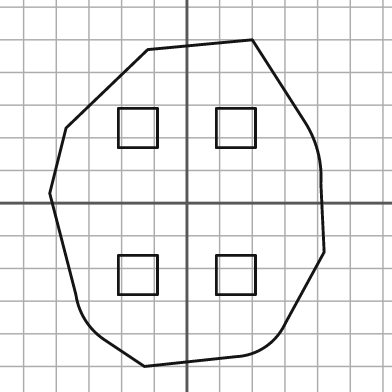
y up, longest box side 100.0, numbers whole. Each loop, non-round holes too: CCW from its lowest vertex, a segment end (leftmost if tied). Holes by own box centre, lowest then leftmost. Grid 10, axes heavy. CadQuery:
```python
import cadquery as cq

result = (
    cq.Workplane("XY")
    .moveTo(-13.0, -50.0)
    .lineTo(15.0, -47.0)
    .threePointArc((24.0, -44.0), (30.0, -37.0))
    .lineTo(42.0, -15.0)
    .lineTo(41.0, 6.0)
    .threePointArc((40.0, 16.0), (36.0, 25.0))
    .lineTo(20.0, 50.0)
    .lineTo(-12.0, 47.0)
    .lineTo(-37.0, 23.0)
    .lineTo(-42.0, 3.0)
    .lineTo(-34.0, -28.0)
    .threePointArc((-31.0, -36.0), (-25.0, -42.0))
    .close()
    .moveTo(-21.0, -28.0)
    .lineTo(-9.0, -28.0)
    .lineTo(-9.0, -16.0)
    .lineTo(-21.0, -16.0)
    .close()
    .moveTo(9.0, -28.0)
    .lineTo(21.0, -28.0)
    .lineTo(21.0, -16.0)
    .lineTo(9.0, -16.0)
    .close()
    .moveTo(-21.0, 17.0)
    .lineTo(-9.0, 17.0)
    .lineTo(-9.0, 29.0)
    .lineTo(-21.0, 29.0)
    .close()
    .moveTo(9.0, 17.0)
    .lineTo(21.0, 17.0)
    .lineTo(21.0, 29.0)
    .lineTo(9.0, 29.0)
    .close()
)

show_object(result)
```